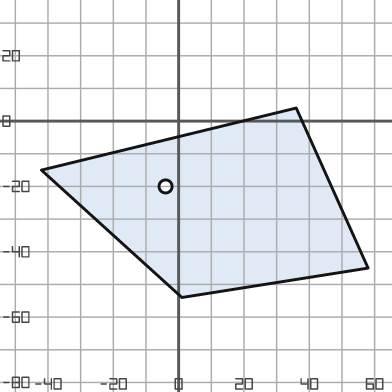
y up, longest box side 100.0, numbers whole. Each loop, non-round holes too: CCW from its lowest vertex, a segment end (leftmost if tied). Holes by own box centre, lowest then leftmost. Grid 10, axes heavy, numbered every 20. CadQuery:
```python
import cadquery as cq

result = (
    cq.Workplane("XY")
    .moveTo(1.0, -54.0)
    .lineTo(58.0, -45.0)
    .lineTo(36.0, 4.0)
    .lineTo(-42.0, -15.0)
    .close()
    .moveTo(-4.0, -20.0)
    .circle(2.0)
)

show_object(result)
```